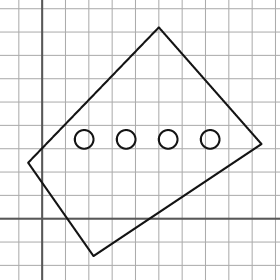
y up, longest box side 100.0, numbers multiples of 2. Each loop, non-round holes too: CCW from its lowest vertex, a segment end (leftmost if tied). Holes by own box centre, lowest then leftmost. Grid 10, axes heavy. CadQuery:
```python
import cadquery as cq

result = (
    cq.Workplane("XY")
    .moveTo(22.0, -16.0)
    .lineTo(94.0, 32.0)
    .lineTo(50.0, 82.0)
    .lineTo(-6.0, 24.0)
    .close()
    .moveTo(18.0, 34.0)
    .circle(4.0)
    .moveTo(36.0, 34.0)
    .circle(4.0)
    .moveTo(54.0, 34.0)
    .circle(4.0)
    .moveTo(72.0, 34.0)
    .circle(4.0)
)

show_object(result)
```